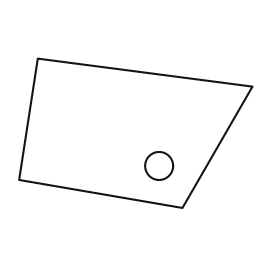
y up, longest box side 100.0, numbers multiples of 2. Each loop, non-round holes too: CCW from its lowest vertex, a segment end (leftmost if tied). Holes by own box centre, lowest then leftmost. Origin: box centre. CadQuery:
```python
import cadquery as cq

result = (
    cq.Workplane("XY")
    .moveTo(20.0, -32.0)
    .lineTo(50.0, 20.0)
    .lineTo(-42.0, 32.0)
    .lineTo(-50.0, -20.0)
    .close()
    .moveTo(10.0, -14.0)
    .circle(6.0)
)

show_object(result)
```